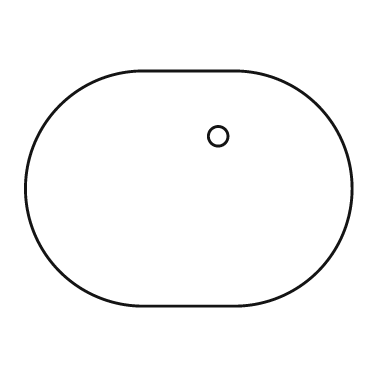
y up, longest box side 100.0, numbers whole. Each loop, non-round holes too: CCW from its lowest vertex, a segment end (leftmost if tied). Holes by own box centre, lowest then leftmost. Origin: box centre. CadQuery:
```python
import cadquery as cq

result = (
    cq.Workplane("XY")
    .moveTo(-14.0, -36.0)
    .lineTo(14.0, -36.0)
    .threePointArc((50.0, 0.0), (14.0, 36.0))
    .lineTo(-14.0, 36.0)
    .threePointArc((-50.0, 0.0), (-14.0, -36.0))
    .close()
    .moveTo(9.0, 16.0)
    .circle(3.0)
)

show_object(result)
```